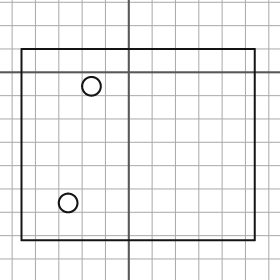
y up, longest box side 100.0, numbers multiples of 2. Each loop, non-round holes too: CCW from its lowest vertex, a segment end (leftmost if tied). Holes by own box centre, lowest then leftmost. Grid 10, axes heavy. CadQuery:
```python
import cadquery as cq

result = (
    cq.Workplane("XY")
    .moveTo(-46.0, -72.0)
    .lineTo(54.0, -72.0)
    .lineTo(54.0, 10.0)
    .lineTo(-46.0, 10.0)
    .close()
    .moveTo(-26.0, -56.0)
    .circle(4.0)
    .moveTo(-16.0, -6.0)
    .circle(4.0)
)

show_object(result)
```